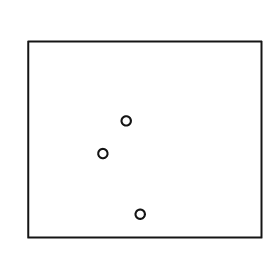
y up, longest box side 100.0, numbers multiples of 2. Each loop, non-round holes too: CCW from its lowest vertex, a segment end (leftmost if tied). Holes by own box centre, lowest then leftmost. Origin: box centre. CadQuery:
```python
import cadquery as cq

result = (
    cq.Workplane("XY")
    .moveTo(-50.0, -42.0)
    .lineTo(50.0, -42.0)
    .lineTo(50.0, 42.0)
    .lineTo(-50.0, 42.0)
    .close()
    .moveTo(-2.0, -32.0)
    .circle(2.0)
    .moveTo(-18.0, -6.0)
    .circle(2.0)
    .moveTo(-8.0, 8.0)
    .circle(2.0)
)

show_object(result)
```